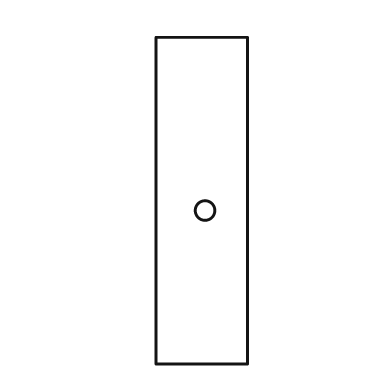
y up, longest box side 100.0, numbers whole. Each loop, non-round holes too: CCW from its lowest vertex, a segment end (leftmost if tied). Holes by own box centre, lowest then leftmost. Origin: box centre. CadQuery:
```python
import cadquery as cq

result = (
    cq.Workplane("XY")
    .moveTo(-14.0, -50.0)
    .lineTo(14.0, -50.0)
    .lineTo(14.0, 50.0)
    .lineTo(-14.0, 50.0)
    .close()
    .moveTo(1.0, -3.0)
    .circle(3.0)
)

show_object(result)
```